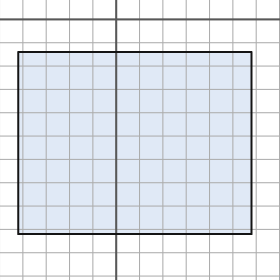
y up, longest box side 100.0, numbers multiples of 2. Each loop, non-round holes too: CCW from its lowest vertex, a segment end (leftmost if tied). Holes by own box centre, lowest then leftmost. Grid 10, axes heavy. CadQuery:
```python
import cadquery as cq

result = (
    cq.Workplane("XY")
    .moveTo(-42.0, -92.0)
    .lineTo(58.0, -92.0)
    .lineTo(58.0, -14.0)
    .lineTo(-42.0, -14.0)
    .close()
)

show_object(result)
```